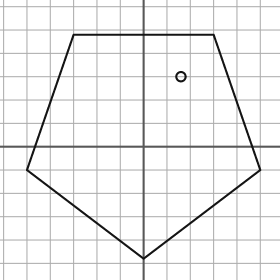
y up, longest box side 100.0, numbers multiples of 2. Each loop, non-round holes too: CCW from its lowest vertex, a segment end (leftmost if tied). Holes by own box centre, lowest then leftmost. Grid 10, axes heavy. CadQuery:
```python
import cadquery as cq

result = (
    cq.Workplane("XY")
    .moveTo(0.0, -48.0)
    .lineTo(50.0, -10.0)
    .lineTo(30.0, 48.0)
    .lineTo(-30.0, 48.0)
    .lineTo(-50.0, -10.0)
    .close()
    .moveTo(16.0, 30.0)
    .circle(2.0)
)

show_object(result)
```